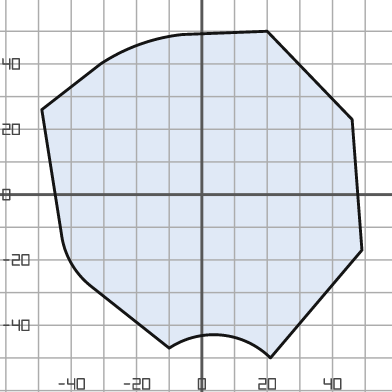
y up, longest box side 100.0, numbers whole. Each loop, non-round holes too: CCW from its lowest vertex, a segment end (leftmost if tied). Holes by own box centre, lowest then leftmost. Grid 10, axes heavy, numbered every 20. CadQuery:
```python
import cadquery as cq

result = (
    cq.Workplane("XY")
    .moveTo(21.0, -50.0)
    .lineTo(49.0, -17.0)
    .lineTo(46.0, 23.0)
    .lineTo(20.0, 50.0)
    .lineTo(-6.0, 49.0)
    .threePointArc((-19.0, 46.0), (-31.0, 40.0))
    .lineTo(-49.0, 26.0)
    .lineTo(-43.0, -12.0)
    .threePointArc((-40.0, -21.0), (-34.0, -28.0))
    .lineTo(-10.0, -47.0)
    .threePointArc((6.0, -43.0), (21.0, -50.0))
    .close()
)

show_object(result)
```